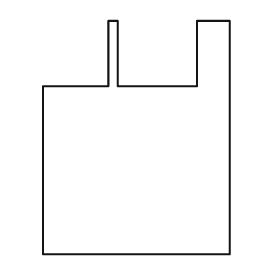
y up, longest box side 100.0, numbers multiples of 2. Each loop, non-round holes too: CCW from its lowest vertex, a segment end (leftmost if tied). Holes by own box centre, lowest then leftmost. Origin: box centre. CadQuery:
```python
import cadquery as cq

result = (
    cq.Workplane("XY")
    .moveTo(-40.0, -50.0)
    .lineTo(40.0, -50.0)
    .lineTo(40.0, 50.0)
    .lineTo(26.0, 50.0)
    .lineTo(26.0, 22.0)
    .lineTo(-8.0, 22.0)
    .lineTo(-8.0, 50.0)
    .lineTo(-12.0, 50.0)
    .lineTo(-12.0, 22.0)
    .lineTo(-40.0, 22.0)
    .close()
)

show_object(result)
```